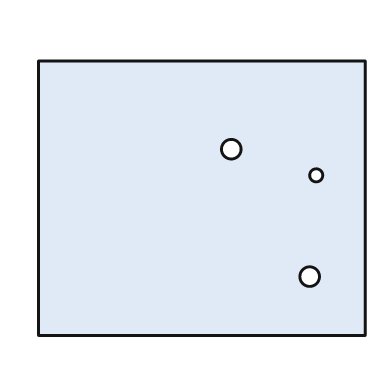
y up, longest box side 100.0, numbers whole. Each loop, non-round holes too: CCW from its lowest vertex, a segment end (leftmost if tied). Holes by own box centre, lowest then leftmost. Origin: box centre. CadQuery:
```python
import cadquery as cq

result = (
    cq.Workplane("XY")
    .moveTo(-50.0, -42.0)
    .lineTo(50.0, -42.0)
    .lineTo(50.0, 42.0)
    .lineTo(-50.0, 42.0)
    .close()
    .moveTo(33.0, -24.0)
    .circle(3.0)
    .moveTo(35.0, 7.0)
    .circle(2.0)
    .moveTo(9.0, 15.0)
    .circle(3.0)
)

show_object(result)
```